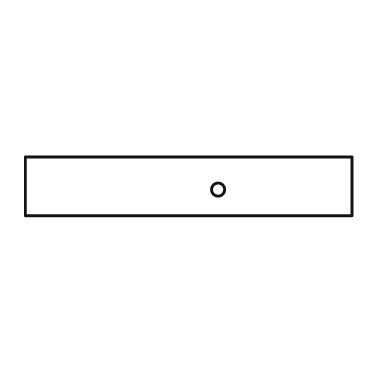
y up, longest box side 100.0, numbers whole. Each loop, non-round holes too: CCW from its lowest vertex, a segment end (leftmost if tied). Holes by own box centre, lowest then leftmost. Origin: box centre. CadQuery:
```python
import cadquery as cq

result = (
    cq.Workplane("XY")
    .moveTo(-50.0, -9.0)
    .lineTo(50.0, -9.0)
    .lineTo(50.0, 9.0)
    .lineTo(-50.0, 9.0)
    .close()
    .moveTo(9.0, -1.0)
    .circle(2.0)
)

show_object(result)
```